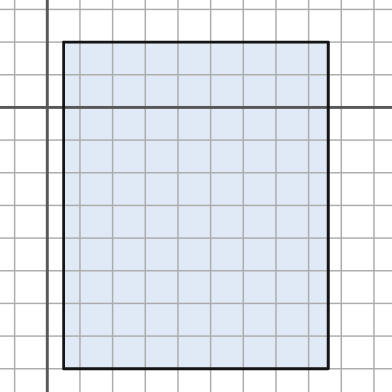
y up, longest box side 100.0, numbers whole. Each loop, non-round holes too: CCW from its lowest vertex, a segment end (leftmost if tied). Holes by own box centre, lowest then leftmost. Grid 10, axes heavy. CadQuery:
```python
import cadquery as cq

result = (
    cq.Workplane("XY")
    .moveTo(5.0, -80.0)
    .lineTo(86.0, -80.0)
    .lineTo(86.0, 20.0)
    .lineTo(5.0, 20.0)
    .close()
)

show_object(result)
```